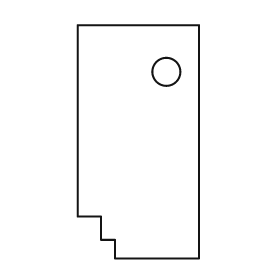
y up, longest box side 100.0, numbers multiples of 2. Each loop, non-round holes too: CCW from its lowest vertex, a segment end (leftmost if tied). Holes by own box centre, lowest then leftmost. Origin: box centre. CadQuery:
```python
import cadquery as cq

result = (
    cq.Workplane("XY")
    .moveTo(-10.0, -50.0)
    .lineTo(26.0, -50.0)
    .lineTo(26.0, 50.0)
    .lineTo(-26.0, 50.0)
    .lineTo(-26.0, -32.0)
    .lineTo(-16.0, -32.0)
    .lineTo(-16.0, -42.0)
    .lineTo(-10.0, -42.0)
    .close()
    .moveTo(12.0, 30.0)
    .circle(6.0)
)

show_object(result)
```